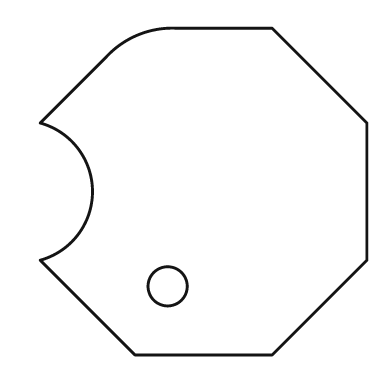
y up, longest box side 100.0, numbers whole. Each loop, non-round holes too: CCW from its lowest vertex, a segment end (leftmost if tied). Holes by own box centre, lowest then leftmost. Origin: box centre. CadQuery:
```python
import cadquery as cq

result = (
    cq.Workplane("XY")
    .moveTo(-21.0, -50.0)
    .lineTo(21.0, -50.0)
    .lineTo(50.0, -21.0)
    .lineTo(50.0, 21.0)
    .lineTo(21.0, 50.0)
    .lineTo(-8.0, 50.0)
    .threePointArc((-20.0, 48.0), (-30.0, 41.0))
    .lineTo(-50.0, 21.0)
    .threePointArc((-34.0, 0.0), (-50.0, -21.0))
    .close()
    .moveTo(-11.0, -29.0)
    .circle(6.0)
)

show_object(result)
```